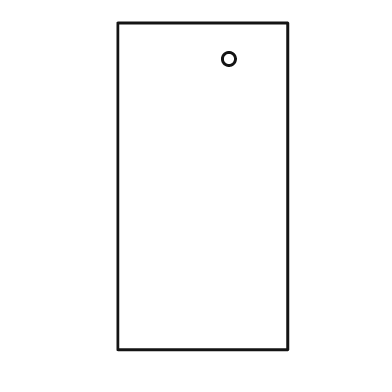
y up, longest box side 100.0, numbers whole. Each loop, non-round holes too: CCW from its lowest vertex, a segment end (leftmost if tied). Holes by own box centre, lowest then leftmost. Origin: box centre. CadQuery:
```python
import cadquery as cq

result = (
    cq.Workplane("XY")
    .moveTo(-26.0, -50.0)
    .lineTo(26.0, -50.0)
    .lineTo(26.0, 50.0)
    .lineTo(-26.0, 50.0)
    .close()
    .moveTo(8.0, 39.0)
    .circle(2.0)
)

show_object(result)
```